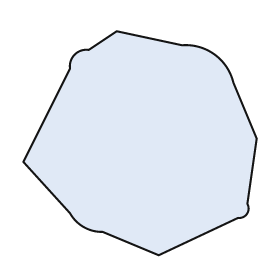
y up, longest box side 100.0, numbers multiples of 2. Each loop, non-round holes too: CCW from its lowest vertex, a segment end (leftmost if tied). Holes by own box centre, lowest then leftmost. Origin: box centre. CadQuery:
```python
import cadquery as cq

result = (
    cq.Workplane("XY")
    .moveTo(8.0, -48.0)
    .lineTo(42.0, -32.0)
    .threePointArc((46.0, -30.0), (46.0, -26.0))
    .lineTo(50.0, 2.0)
    .lineTo(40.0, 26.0)
    .threePointArc((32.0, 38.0), (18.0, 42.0))
    .lineTo(-10.0, 48.0)
    .lineTo(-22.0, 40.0)
    .threePointArc((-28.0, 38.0), (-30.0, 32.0))
    .lineTo(-50.0, -8.0)
    .lineTo(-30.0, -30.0)
    .threePointArc((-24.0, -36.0), (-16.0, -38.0))
    .close()
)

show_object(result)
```